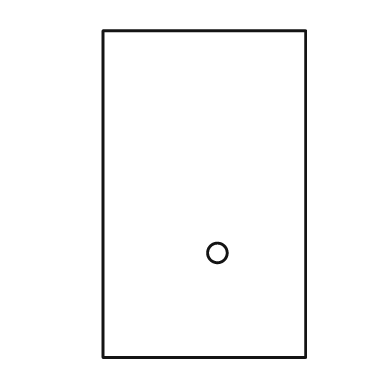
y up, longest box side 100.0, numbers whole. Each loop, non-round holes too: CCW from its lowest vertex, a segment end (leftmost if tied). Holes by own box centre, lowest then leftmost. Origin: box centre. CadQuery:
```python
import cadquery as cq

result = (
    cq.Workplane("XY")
    .moveTo(-31.0, -50.0)
    .lineTo(31.0, -50.0)
    .lineTo(31.0, 50.0)
    .lineTo(-31.0, 50.0)
    .close()
    .moveTo(4.0, -18.0)
    .circle(3.0)
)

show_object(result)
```